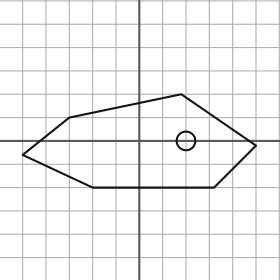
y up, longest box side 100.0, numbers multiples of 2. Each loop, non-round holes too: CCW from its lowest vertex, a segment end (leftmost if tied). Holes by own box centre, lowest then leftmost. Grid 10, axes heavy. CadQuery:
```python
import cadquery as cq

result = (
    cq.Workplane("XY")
    .moveTo(-20.0, -20.0)
    .lineTo(32.0, -20.0)
    .lineTo(50.0, -2.0)
    .lineTo(18.0, 20.0)
    .lineTo(-30.0, 10.0)
    .lineTo(-50.0, -6.0)
    .close()
    .moveTo(20.0, 0.0)
    .circle(4.0)
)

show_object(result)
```